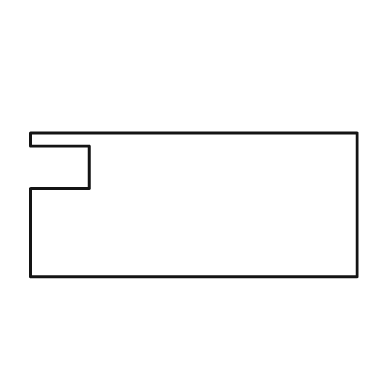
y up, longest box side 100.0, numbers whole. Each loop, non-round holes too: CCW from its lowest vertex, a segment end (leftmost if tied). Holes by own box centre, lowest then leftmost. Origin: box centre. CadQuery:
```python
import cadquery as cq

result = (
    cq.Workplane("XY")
    .moveTo(-50.0, -22.0)
    .lineTo(50.0, -22.0)
    .lineTo(50.0, 22.0)
    .lineTo(-50.0, 22.0)
    .lineTo(-50.0, 18.0)
    .lineTo(-32.0, 18.0)
    .lineTo(-32.0, 5.0)
    .lineTo(-50.0, 5.0)
    .close()
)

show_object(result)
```